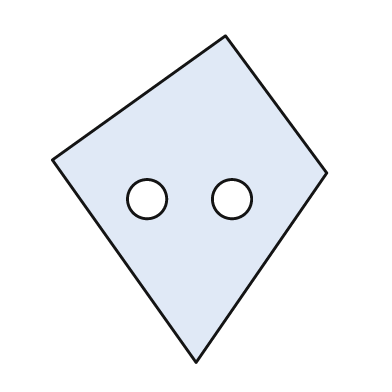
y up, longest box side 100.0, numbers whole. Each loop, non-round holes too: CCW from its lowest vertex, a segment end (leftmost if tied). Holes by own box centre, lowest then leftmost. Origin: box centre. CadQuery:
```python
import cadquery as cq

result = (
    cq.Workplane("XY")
    .moveTo(2.0, -50.0)
    .lineTo(42.0, 8.0)
    .lineTo(11.0, 50.0)
    .lineTo(-42.0, 12.0)
    .close()
    .moveTo(-13.0, 0.0)
    .circle(6.0)
    .moveTo(13.0, 0.0)
    .circle(6.0)
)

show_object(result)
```